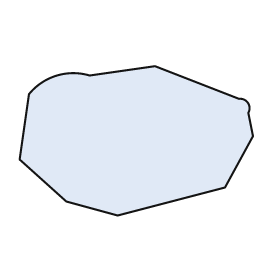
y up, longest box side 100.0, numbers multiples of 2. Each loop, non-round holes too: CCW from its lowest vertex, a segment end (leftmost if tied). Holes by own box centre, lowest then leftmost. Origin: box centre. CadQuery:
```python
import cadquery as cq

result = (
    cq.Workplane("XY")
    .moveTo(-8.0, -32.0)
    .lineTo(38.0, -20.0)
    .lineTo(50.0, 2.0)
    .lineTo(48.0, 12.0)
    .threePointArc((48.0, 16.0), (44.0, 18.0))
    .lineTo(8.0, 32.0)
    .lineTo(-20.0, 28.0)
    .threePointArc((-34.0, 28.0), (-46.0, 20.0))
    .lineTo(-50.0, -8.0)
    .lineTo(-30.0, -26.0)
    .close()
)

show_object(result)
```